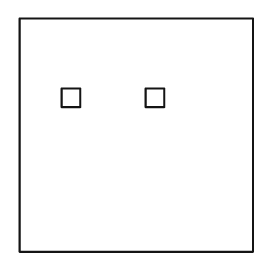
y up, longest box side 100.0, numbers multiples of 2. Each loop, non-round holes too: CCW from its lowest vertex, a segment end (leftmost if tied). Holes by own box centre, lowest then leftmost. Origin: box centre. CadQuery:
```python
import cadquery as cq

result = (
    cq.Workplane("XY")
    .moveTo(-50.0, -50.0)
    .lineTo(50.0, -50.0)
    .lineTo(50.0, 50.0)
    .lineTo(-50.0, 50.0)
    .close()
    .moveTo(-32.0, 12.0)
    .lineTo(-24.0, 12.0)
    .lineTo(-24.0, 20.0)
    .lineTo(-32.0, 20.0)
    .close()
    .moveTo(4.0, 12.0)
    .lineTo(12.0, 12.0)
    .lineTo(12.0, 20.0)
    .lineTo(4.0, 20.0)
    .close()
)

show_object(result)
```